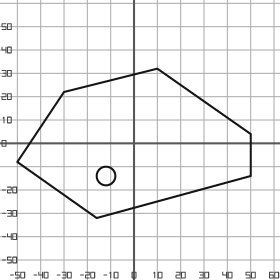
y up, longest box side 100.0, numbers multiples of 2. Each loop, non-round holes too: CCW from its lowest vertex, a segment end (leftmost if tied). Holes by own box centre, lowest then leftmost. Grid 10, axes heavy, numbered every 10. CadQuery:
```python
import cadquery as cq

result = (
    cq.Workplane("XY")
    .moveTo(-16.0, -32.0)
    .lineTo(50.0, -14.0)
    .lineTo(50.0, 4.0)
    .lineTo(10.0, 32.0)
    .lineTo(-30.0, 22.0)
    .lineTo(-50.0, -8.0)
    .close()
    .moveTo(-12.0, -14.0)
    .circle(4.0)
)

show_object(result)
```